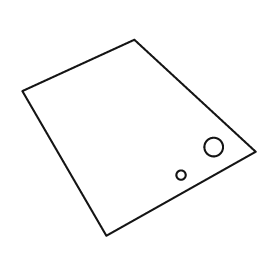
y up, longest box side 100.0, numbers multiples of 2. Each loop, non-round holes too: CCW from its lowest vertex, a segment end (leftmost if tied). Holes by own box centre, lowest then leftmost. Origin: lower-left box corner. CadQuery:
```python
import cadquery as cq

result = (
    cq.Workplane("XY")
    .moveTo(36.0, 0.0)
    .lineTo(100.0, 36.0)
    .lineTo(48.0, 84.0)
    .lineTo(0.0, 62.0)
    .close()
    .moveTo(68.0, 26.0)
    .circle(2.0)
    .moveTo(82.0, 38.0)
    .circle(4.0)
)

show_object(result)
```